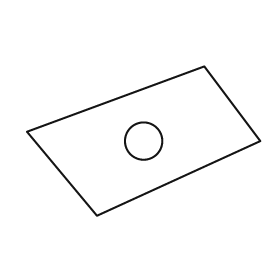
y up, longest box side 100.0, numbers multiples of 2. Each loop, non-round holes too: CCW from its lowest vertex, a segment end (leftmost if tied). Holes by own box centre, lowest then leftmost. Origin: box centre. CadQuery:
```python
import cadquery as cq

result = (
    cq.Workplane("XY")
    .moveTo(-20.0, -32.0)
    .lineTo(50.0, 0.0)
    .lineTo(26.0, 32.0)
    .lineTo(-50.0, 4.0)
    .close()
    .moveTo(0.0, 0.0)
    .circle(8.0)
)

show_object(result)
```